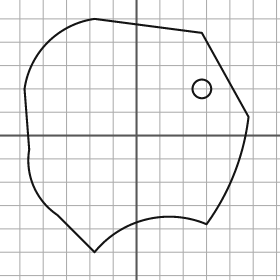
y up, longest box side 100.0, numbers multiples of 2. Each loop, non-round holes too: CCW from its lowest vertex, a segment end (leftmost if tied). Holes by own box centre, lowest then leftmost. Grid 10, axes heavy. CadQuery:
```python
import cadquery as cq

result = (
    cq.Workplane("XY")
    .moveTo(-18.0, -50.0)
    .threePointArc((4.0, -36.0), (30.0, -38.0))
    .threePointArc((42.0, -16.0), (48.0, 8.0))
    .lineTo(28.0, 44.0)
    .lineTo(-18.0, 50.0)
    .threePointArc((-38.0, 40.0), (-48.0, 20.0))
    .lineTo(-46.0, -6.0)
    .threePointArc((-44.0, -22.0), (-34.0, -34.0))
    .close()
    .moveTo(28.0, 20.0)
    .circle(4.0)
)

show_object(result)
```